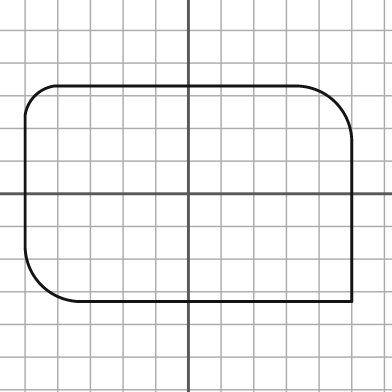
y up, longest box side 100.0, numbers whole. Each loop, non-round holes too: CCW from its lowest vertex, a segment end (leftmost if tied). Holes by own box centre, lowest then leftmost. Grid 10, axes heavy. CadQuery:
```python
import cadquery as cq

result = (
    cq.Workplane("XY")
    .moveTo(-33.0, -33.0)
    .lineTo(50.0, -33.0)
    .lineTo(50.0, 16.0)
    .threePointArc((45.0, 28.0), (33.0, 33.0))
    .lineTo(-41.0, 33.0)
    .threePointArc((-47.0, 30.0), (-50.0, 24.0))
    .lineTo(-50.0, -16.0)
    .threePointArc((-45.0, -28.0), (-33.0, -33.0))
    .close()
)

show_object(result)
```